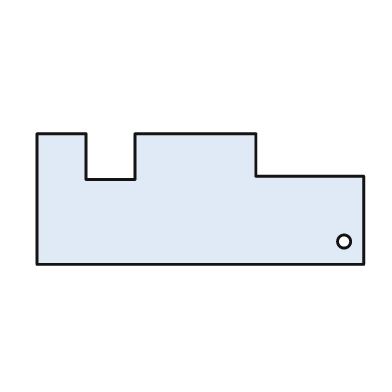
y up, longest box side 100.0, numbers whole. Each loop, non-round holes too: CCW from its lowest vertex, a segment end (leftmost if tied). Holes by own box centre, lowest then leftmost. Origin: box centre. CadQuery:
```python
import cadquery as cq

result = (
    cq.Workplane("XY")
    .moveTo(-50.0, -20.0)
    .lineTo(50.0, -20.0)
    .lineTo(50.0, 7.0)
    .lineTo(17.0, 7.0)
    .lineTo(17.0, 20.0)
    .lineTo(-20.0, 20.0)
    .lineTo(-20.0, 6.0)
    .lineTo(-35.0, 6.0)
    .lineTo(-35.0, 20.0)
    .lineTo(-50.0, 20.0)
    .close()
    .moveTo(44.0, -13.0)
    .circle(2.0)
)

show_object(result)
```